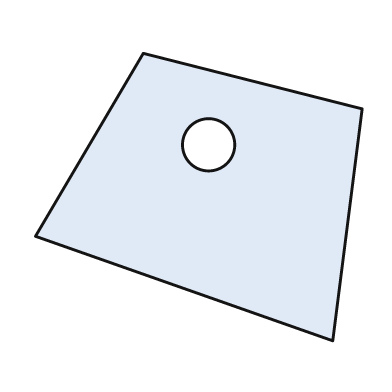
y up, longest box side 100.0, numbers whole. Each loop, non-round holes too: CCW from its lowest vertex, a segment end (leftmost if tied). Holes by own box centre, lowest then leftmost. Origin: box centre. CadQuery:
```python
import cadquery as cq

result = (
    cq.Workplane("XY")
    .moveTo(41.0, -44.0)
    .lineTo(50.0, 27.0)
    .lineTo(-17.0, 44.0)
    .lineTo(-50.0, -12.0)
    .close()
    .moveTo(3.0, 16.0)
    .circle(8.0)
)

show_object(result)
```